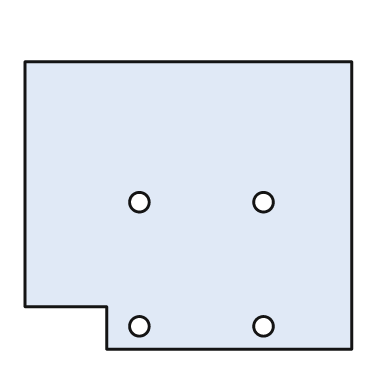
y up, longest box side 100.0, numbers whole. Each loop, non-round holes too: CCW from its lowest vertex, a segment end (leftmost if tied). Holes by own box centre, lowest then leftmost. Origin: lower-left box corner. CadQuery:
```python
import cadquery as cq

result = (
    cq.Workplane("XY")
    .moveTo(25.0, 0.0)
    .lineTo(100.0, 0.0)
    .lineTo(100.0, 88.0)
    .lineTo(0.0, 88.0)
    .lineTo(0.0, 13.0)
    .lineTo(25.0, 13.0)
    .close()
    .moveTo(35.0, 7.0)
    .circle(3.0)
    .moveTo(73.0, 7.0)
    .circle(3.0)
    .moveTo(35.0, 45.0)
    .circle(3.0)
    .moveTo(73.0, 45.0)
    .circle(3.0)
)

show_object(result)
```